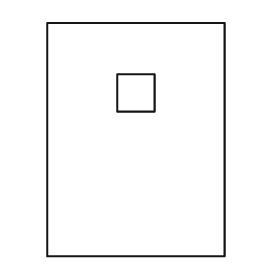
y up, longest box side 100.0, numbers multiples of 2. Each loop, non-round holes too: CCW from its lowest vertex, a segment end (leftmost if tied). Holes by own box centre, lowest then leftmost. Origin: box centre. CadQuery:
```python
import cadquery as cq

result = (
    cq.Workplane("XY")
    .moveTo(-38.0, -50.0)
    .lineTo(38.0, -50.0)
    .lineTo(38.0, 50.0)
    .lineTo(-38.0, 50.0)
    .close()
    .moveTo(-8.0, 12.0)
    .lineTo(8.0, 12.0)
    .lineTo(8.0, 28.0)
    .lineTo(-8.0, 28.0)
    .close()
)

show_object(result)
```